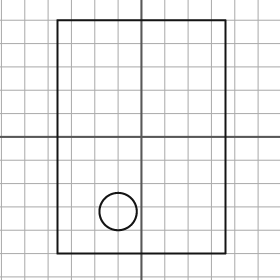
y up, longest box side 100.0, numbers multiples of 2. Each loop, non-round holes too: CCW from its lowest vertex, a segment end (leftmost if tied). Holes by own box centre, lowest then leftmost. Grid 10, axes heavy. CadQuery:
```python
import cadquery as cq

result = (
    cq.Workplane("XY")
    .moveTo(-36.0, -50.0)
    .lineTo(36.0, -50.0)
    .lineTo(36.0, 50.0)
    .lineTo(-36.0, 50.0)
    .close()
    .moveTo(-10.0, -32.0)
    .circle(8.0)
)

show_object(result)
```